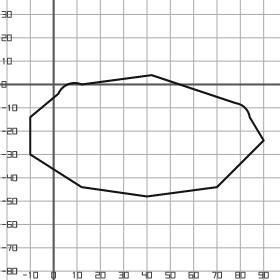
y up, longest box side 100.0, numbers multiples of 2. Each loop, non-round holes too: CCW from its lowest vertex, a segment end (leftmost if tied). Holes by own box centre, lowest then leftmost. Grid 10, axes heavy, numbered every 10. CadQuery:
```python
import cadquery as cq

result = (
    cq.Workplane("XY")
    .moveTo(40.0, -48.0)
    .lineTo(70.0, -44.0)
    .lineTo(90.0, -24.0)
    .lineTo(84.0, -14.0)
    .threePointArc((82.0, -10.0), (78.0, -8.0))
    .lineTo(42.0, 4.0)
    .lineTo(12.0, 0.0)
    .threePointArc((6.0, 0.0), (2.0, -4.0))
    .lineTo(-10.0, -14.0)
    .lineTo(-10.0, -30.0)
    .lineTo(12.0, -44.0)
    .close()
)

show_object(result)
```